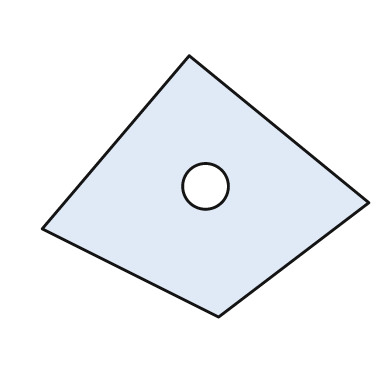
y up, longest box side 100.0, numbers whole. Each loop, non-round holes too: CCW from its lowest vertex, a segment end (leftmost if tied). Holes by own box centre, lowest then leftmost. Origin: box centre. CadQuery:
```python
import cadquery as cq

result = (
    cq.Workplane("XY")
    .moveTo(4.0, -40.0)
    .lineTo(50.0, -5.0)
    .lineTo(-5.0, 40.0)
    .lineTo(-50.0, -13.0)
    .close()
    .moveTo(0.0, 0.0)
    .circle(7.0)
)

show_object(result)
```